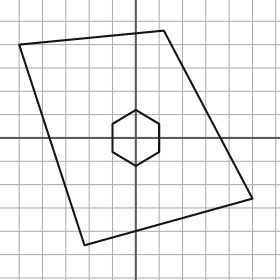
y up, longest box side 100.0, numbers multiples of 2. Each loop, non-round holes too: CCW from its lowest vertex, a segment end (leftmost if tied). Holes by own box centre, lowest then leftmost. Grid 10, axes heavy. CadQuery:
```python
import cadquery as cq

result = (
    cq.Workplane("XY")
    .moveTo(-22.0, -46.0)
    .lineTo(50.0, -26.0)
    .lineTo(12.0, 46.0)
    .lineTo(-50.0, 40.0)
    .close()
    .moveTo(0.0, -12.0)
    .lineTo(10.0, -6.0)
    .lineTo(10.0, 6.0)
    .lineTo(0.0, 12.0)
    .lineTo(-10.0, 6.0)
    .lineTo(-10.0, -6.0)
    .close()
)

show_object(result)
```